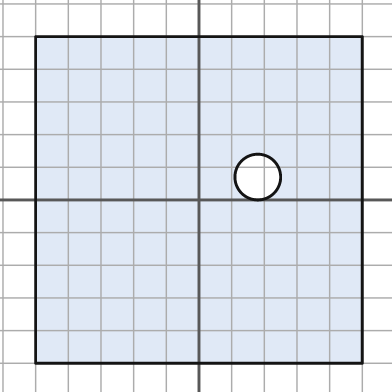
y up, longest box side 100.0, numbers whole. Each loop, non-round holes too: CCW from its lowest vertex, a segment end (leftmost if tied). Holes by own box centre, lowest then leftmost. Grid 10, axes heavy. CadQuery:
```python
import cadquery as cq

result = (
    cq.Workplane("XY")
    .moveTo(-50.0, -50.0)
    .lineTo(50.0, -50.0)
    .lineTo(50.0, 50.0)
    .lineTo(-50.0, 50.0)
    .close()
    .moveTo(18.0, 7.0)
    .circle(7.0)
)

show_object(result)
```